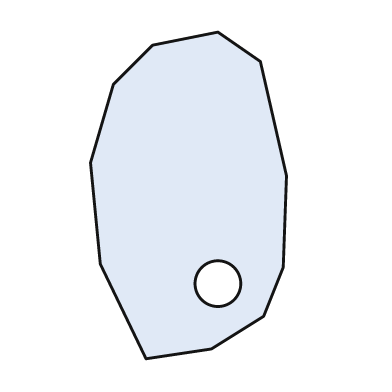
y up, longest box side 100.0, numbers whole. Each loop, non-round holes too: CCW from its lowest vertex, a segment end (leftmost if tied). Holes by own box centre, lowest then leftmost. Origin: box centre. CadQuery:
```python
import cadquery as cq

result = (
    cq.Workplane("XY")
    .moveTo(-13.0, -50.0)
    .lineTo(7.0, -47.0)
    .lineTo(23.0, -37.0)
    .lineTo(29.0, -22.0)
    .lineTo(30.0, 6.0)
    .lineTo(22.0, 41.0)
    .lineTo(9.0, 50.0)
    .lineTo(-11.0, 46.0)
    .lineTo(-23.0, 34.0)
    .lineTo(-30.0, 10.0)
    .lineTo(-27.0, -21.0)
    .close()
    .moveTo(9.0, -27.0)
    .circle(7.0)
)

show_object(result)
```